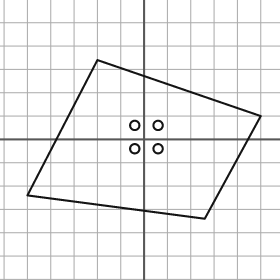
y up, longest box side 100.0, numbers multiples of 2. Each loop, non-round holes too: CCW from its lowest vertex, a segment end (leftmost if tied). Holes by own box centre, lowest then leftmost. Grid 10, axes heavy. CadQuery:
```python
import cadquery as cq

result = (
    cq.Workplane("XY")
    .moveTo(26.0, -34.0)
    .lineTo(50.0, 10.0)
    .lineTo(-20.0, 34.0)
    .lineTo(-50.0, -24.0)
    .close()
    .moveTo(-4.0, -4.0)
    .circle(2.0)
    .moveTo(6.0, -4.0)
    .circle(2.0)
    .moveTo(-4.0, 6.0)
    .circle(2.0)
    .moveTo(6.0, 6.0)
    .circle(2.0)
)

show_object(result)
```